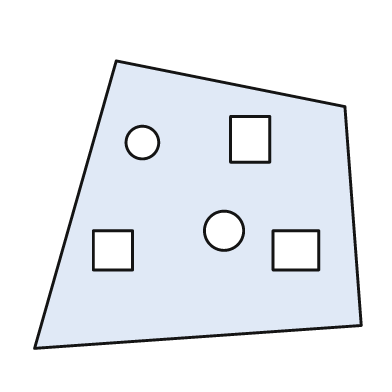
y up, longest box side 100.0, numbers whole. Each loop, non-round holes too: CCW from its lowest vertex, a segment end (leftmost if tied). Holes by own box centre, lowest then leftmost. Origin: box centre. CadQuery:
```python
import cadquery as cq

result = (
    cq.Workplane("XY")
    .moveTo(-50.0, -44.0)
    .lineTo(50.0, -37.0)
    .lineTo(45.0, 30.0)
    .lineTo(-25.0, 44.0)
    .close()
    .moveTo(-32.0, -20.0)
    .lineTo(-20.0, -20.0)
    .lineTo(-20.0, -8.0)
    .lineTo(-32.0, -8.0)
    .close()
    .moveTo(23.0, -20.0)
    .lineTo(37.0, -20.0)
    .lineTo(37.0, -8.0)
    .lineTo(23.0, -8.0)
    .close()
    .moveTo(8.0, -8.0)
    .circle(6.0)
    .moveTo(-17.0, 19.0)
    .circle(5.0)
    .moveTo(10.0, 13.0)
    .lineTo(22.0, 13.0)
    .lineTo(22.0, 27.0)
    .lineTo(10.0, 27.0)
    .close()
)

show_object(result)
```